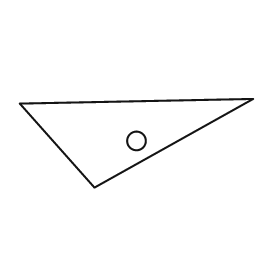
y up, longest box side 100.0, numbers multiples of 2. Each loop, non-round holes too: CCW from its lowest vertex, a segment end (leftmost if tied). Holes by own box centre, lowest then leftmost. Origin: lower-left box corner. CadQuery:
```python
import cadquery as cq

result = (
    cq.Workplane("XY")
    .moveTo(32.0, 0.0)
    .lineTo(100.0, 38.0)
    .lineTo(0.0, 36.0)
    .close()
    .moveTo(50.0, 20.0)
    .circle(4.0)
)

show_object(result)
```